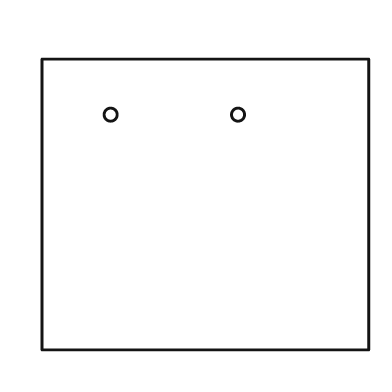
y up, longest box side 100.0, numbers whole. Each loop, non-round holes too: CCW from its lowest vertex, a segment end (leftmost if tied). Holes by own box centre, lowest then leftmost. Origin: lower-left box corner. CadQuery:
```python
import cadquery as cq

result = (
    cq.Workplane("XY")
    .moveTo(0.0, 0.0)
    .lineTo(100.0, 0.0)
    .lineTo(100.0, 89.0)
    .lineTo(0.0, 89.0)
    .close()
    .moveTo(21.0, 72.0)
    .circle(2.0)
    .moveTo(60.0, 72.0)
    .circle(2.0)
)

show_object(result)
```